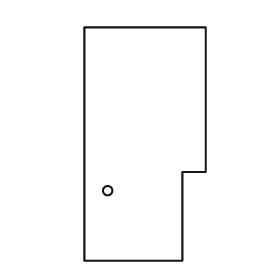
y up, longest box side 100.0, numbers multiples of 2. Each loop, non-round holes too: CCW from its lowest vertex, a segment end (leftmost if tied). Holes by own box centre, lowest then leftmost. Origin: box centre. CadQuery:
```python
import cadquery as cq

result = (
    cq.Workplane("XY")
    .moveTo(-26.0, -50.0)
    .lineTo(16.0, -50.0)
    .lineTo(16.0, -12.0)
    .lineTo(26.0, -12.0)
    .lineTo(26.0, 50.0)
    .lineTo(-26.0, 50.0)
    .close()
    .moveTo(-16.0, -20.0)
    .circle(2.0)
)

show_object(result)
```